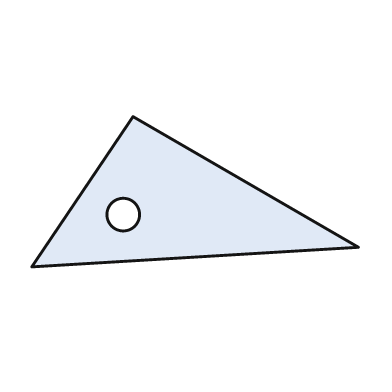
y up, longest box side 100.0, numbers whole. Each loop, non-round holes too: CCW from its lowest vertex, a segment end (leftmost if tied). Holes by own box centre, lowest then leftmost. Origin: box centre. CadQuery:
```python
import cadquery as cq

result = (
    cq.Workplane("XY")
    .moveTo(-50.0, -23.0)
    .lineTo(50.0, -17.0)
    .lineTo(-19.0, 23.0)
    .close()
    .moveTo(-22.0, -7.0)
    .circle(5.0)
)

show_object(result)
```